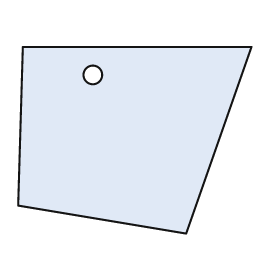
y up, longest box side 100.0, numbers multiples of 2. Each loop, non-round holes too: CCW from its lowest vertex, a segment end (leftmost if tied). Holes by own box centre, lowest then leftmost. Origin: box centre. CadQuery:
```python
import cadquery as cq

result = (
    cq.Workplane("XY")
    .moveTo(22.0, -40.0)
    .lineTo(50.0, 40.0)
    .lineTo(-48.0, 40.0)
    .lineTo(-50.0, -28.0)
    .close()
    .moveTo(-18.0, 28.0)
    .circle(4.0)
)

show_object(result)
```